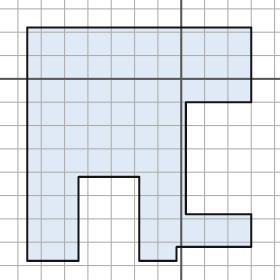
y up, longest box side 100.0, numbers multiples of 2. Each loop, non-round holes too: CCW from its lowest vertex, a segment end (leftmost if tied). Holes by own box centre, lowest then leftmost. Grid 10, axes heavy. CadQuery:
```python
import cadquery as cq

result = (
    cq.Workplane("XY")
    .moveTo(-66.0, -78.0)
    .lineTo(-44.0, -78.0)
    .lineTo(-44.0, -42.0)
    .lineTo(-18.0, -42.0)
    .lineTo(-18.0, -78.0)
    .lineTo(-2.0, -78.0)
    .lineTo(-2.0, -72.0)
    .lineTo(30.0, -72.0)
    .lineTo(30.0, -58.0)
    .lineTo(2.0, -58.0)
    .lineTo(2.0, -10.0)
    .lineTo(30.0, -10.0)
    .lineTo(30.0, 22.0)
    .lineTo(-66.0, 22.0)
    .close()
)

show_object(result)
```